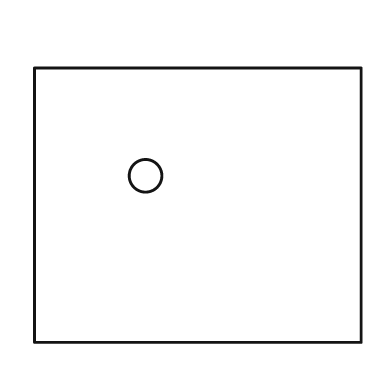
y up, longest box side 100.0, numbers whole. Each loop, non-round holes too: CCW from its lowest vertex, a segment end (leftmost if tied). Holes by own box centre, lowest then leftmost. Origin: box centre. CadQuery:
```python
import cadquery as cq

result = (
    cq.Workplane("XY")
    .moveTo(-50.0, -42.0)
    .lineTo(50.0, -42.0)
    .lineTo(50.0, 42.0)
    .lineTo(-50.0, 42.0)
    .close()
    .moveTo(-16.0, 9.0)
    .circle(5.0)
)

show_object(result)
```